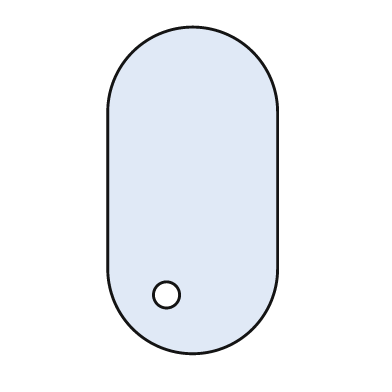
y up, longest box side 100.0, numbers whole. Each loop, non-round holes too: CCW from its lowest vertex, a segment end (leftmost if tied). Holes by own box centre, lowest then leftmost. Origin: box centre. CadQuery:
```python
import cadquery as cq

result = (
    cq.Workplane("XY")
    .moveTo(-26.0, -24.0)
    .threePointArc((0.0, -50.0), (26.0, -24.0))
    .lineTo(26.0, 24.0)
    .threePointArc((0.0, 50.0), (-26.0, 24.0))
    .close()
    .moveTo(-8.0, -32.0)
    .circle(4.0)
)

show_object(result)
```